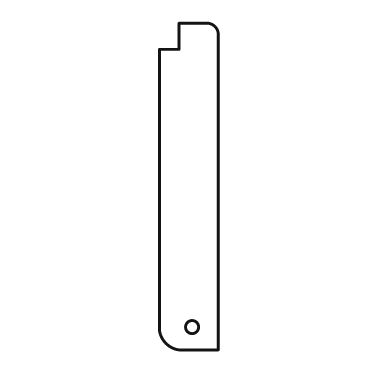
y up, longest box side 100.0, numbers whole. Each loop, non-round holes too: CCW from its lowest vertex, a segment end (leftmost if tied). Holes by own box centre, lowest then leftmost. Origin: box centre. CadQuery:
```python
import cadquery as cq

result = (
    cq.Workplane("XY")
    .moveTo(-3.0, -50.0)
    .lineTo(9.0, -50.0)
    .lineTo(9.0, 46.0)
    .threePointArc((8.0, 49.0), (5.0, 50.0))
    .lineTo(-3.0, 50.0)
    .lineTo(-3.0, 42.0)
    .lineTo(-9.0, 42.0)
    .lineTo(-9.0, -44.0)
    .threePointArc((-7.0, -48.0), (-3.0, -50.0))
    .close()
    .moveTo(1.0, -43.0)
    .circle(2.0)
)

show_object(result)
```